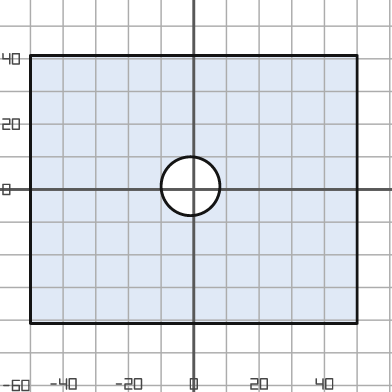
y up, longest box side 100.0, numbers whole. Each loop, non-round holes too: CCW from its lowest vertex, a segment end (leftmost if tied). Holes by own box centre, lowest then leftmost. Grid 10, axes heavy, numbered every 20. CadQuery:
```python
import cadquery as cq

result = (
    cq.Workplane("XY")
    .moveTo(-50.0, -41.0)
    .lineTo(50.0, -41.0)
    .lineTo(50.0, 41.0)
    .lineTo(-50.0, 41.0)
    .close()
    .moveTo(-1.0, 1.0)
    .circle(9.0)
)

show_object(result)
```